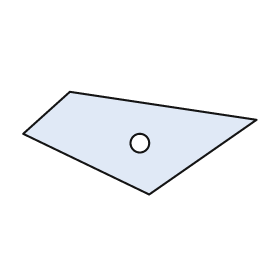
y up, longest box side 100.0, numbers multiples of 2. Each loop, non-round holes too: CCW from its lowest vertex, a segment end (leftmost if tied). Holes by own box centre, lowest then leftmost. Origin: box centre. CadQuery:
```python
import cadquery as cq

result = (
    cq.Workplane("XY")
    .moveTo(4.0, -22.0)
    .lineTo(50.0, 10.0)
    .lineTo(-30.0, 22.0)
    .lineTo(-50.0, 4.0)
    .close()
    .moveTo(0.0, 0.0)
    .circle(4.0)
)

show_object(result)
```